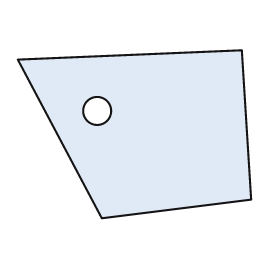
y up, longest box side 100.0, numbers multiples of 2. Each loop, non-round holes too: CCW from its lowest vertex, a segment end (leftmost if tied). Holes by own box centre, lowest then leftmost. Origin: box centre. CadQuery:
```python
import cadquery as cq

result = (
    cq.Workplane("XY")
    .moveTo(-14.0, -36.0)
    .lineTo(50.0, -28.0)
    .lineTo(46.0, 36.0)
    .lineTo(-50.0, 32.0)
    .close()
    .moveTo(-16.0, 10.0)
    .circle(6.0)
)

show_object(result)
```